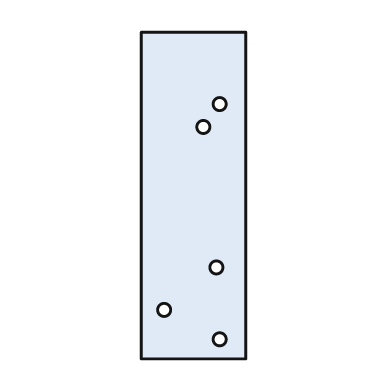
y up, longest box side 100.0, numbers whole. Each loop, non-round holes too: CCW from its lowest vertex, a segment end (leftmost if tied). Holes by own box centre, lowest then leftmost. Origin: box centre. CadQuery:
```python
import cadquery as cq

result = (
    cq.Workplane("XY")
    .moveTo(-16.0, -50.0)
    .lineTo(16.0, -50.0)
    .lineTo(16.0, 50.0)
    .lineTo(-16.0, 50.0)
    .close()
    .moveTo(8.0, -44.0)
    .circle(2.0)
    .moveTo(-9.0, -35.0)
    .circle(2.0)
    .moveTo(7.0, -22.0)
    .circle(2.0)
    .moveTo(3.0, 21.0)
    .circle(2.0)
    .moveTo(8.0, 28.0)
    .circle(2.0)
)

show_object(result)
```